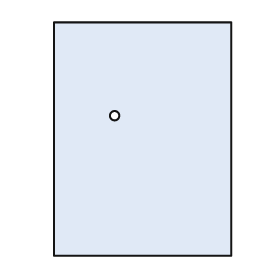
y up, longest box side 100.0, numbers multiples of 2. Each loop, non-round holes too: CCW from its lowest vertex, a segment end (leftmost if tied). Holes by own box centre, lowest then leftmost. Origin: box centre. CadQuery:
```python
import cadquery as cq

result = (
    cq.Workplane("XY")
    .moveTo(-38.0, -50.0)
    .lineTo(38.0, -50.0)
    .lineTo(38.0, 50.0)
    .lineTo(-38.0, 50.0)
    .close()
    .moveTo(-12.0, 10.0)
    .circle(2.0)
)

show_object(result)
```